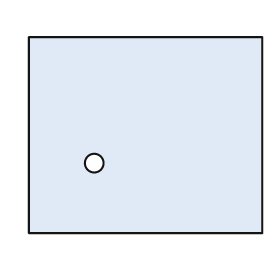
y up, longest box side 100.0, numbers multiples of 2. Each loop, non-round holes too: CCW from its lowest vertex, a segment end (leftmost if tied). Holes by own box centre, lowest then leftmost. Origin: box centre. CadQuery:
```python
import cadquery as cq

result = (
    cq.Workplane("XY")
    .moveTo(-50.0, -42.0)
    .lineTo(50.0, -42.0)
    .lineTo(50.0, 42.0)
    .lineTo(-50.0, 42.0)
    .close()
    .moveTo(-22.0, -12.0)
    .circle(4.0)
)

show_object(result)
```